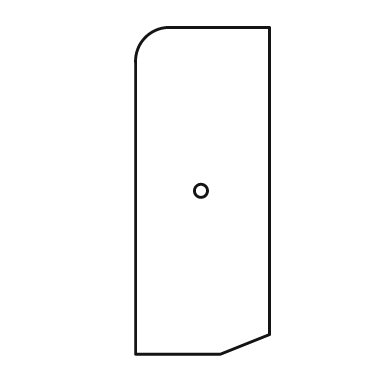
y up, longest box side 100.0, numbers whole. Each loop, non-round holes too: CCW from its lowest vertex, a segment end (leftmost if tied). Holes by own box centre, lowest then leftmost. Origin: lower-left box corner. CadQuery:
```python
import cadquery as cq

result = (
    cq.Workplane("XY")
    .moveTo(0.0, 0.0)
    .lineTo(26.0, 0.0)
    .lineTo(41.0, 6.0)
    .lineTo(41.0, 100.0)
    .lineTo(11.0, 100.0)
    .threePointArc((3.0, 97.0), (0.0, 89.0))
    .close()
    .moveTo(20.0, 50.0)
    .circle(2.0)
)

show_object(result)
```